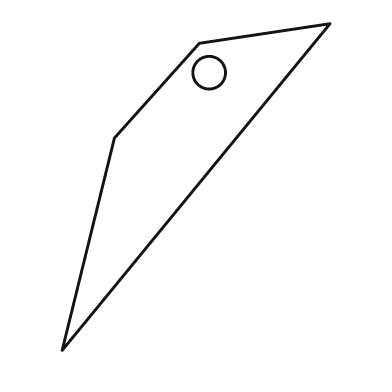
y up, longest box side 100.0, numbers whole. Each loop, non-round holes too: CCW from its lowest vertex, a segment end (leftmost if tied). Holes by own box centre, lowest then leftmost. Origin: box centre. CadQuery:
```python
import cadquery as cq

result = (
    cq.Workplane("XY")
    .moveTo(-41.0, -50.0)
    .lineTo(41.0, 50.0)
    .lineTo(1.0, 44.0)
    .lineTo(-25.0, 15.0)
    .close()
    .moveTo(4.0, 35.0)
    .circle(5.0)
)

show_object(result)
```